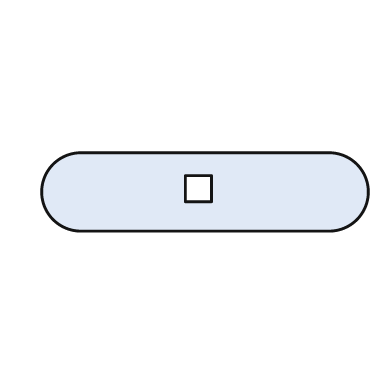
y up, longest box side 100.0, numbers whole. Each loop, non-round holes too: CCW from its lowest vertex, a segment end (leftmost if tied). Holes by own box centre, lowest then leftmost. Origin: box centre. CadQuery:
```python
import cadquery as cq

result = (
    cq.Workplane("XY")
    .moveTo(-38.0, -12.0)
    .lineTo(38.0, -12.0)
    .threePointArc((50.0, 0.0), (38.0, 12.0))
    .lineTo(-38.0, 12.0)
    .threePointArc((-50.0, 0.0), (-38.0, -12.0))
    .close()
    .moveTo(-6.0, -3.0)
    .lineTo(2.0, -3.0)
    .lineTo(2.0, 5.0)
    .lineTo(-6.0, 5.0)
    .close()
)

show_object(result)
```